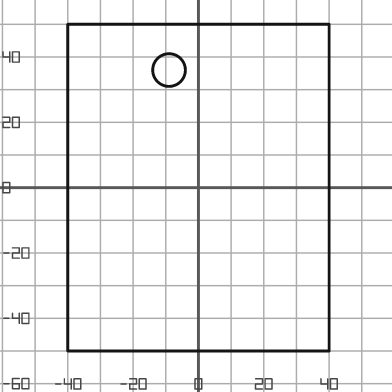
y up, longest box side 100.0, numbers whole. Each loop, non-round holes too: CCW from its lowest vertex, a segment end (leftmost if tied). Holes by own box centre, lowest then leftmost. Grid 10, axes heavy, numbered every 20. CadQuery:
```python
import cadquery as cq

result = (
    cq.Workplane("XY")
    .moveTo(-40.0, -50.0)
    .lineTo(40.0, -50.0)
    .lineTo(40.0, 50.0)
    .lineTo(-40.0, 50.0)
    .close()
    .moveTo(-9.0, 36.0)
    .circle(5.0)
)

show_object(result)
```